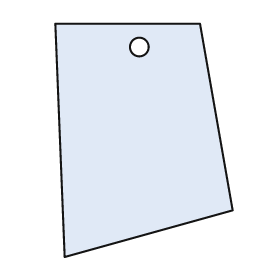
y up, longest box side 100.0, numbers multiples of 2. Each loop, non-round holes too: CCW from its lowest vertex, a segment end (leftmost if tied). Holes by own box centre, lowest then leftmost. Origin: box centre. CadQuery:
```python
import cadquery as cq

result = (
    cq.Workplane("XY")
    .moveTo(-34.0, -50.0)
    .lineTo(38.0, -30.0)
    .lineTo(24.0, 50.0)
    .lineTo(-38.0, 50.0)
    .close()
    .moveTo(-2.0, 40.0)
    .circle(4.0)
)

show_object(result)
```